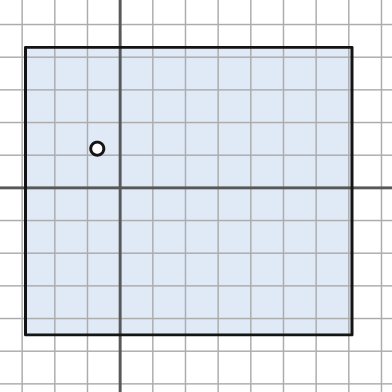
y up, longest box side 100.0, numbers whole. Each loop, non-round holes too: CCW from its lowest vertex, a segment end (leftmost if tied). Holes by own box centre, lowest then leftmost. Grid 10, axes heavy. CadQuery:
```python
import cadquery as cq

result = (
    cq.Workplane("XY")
    .moveTo(-29.0, -45.0)
    .lineTo(71.0, -45.0)
    .lineTo(71.0, 43.0)
    .lineTo(-29.0, 43.0)
    .close()
    .moveTo(-7.0, 12.0)
    .circle(2.0)
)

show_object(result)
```